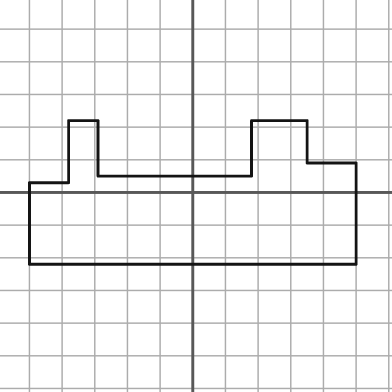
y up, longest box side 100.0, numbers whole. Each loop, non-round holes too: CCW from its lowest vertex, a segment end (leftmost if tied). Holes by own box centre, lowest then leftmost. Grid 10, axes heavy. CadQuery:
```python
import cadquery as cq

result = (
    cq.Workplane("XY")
    .moveTo(-50.0, -22.0)
    .lineTo(50.0, -22.0)
    .lineTo(50.0, 9.0)
    .lineTo(35.0, 9.0)
    .lineTo(35.0, 22.0)
    .lineTo(18.0, 22.0)
    .lineTo(18.0, 5.0)
    .lineTo(-29.0, 5.0)
    .lineTo(-29.0, 22.0)
    .lineTo(-38.0, 22.0)
    .lineTo(-38.0, 3.0)
    .lineTo(-50.0, 3.0)
    .close()
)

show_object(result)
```